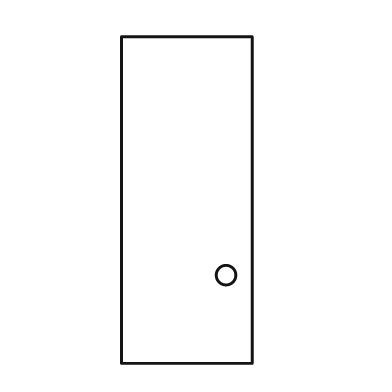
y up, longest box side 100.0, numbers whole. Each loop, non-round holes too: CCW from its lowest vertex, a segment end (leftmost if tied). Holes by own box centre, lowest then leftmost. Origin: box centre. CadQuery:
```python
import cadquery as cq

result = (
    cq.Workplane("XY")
    .moveTo(-20.0, -50.0)
    .lineTo(20.0, -50.0)
    .lineTo(20.0, 50.0)
    .lineTo(-20.0, 50.0)
    .close()
    .moveTo(12.0, -23.0)
    .circle(3.0)
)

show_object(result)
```